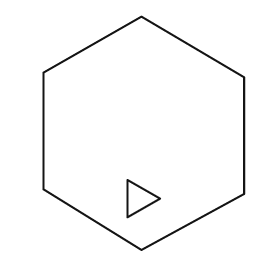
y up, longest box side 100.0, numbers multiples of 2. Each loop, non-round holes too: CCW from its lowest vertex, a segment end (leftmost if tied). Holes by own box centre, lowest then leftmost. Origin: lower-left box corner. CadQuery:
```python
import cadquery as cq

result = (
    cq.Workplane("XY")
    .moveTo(42.0, 0.0)
    .lineTo(86.0, 24.0)
    .lineTo(86.0, 74.0)
    .lineTo(42.0, 100.0)
    .lineTo(0.0, 76.0)
    .lineTo(0.0, 26.0)
    .close()
    .moveTo(36.0, 14.0)
    .lineTo(50.0, 22.0)
    .lineTo(36.0, 30.0)
    .close()
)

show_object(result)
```